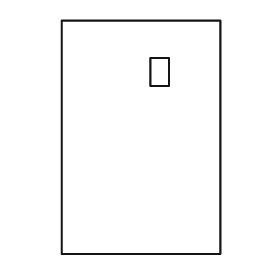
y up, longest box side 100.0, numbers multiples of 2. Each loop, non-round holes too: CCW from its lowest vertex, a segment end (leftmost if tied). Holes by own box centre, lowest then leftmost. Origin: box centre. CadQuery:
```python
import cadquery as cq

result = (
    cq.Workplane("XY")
    .moveTo(-34.0, -50.0)
    .lineTo(34.0, -50.0)
    .lineTo(34.0, 50.0)
    .lineTo(-34.0, 50.0)
    .close()
    .moveTo(4.0, 22.0)
    .lineTo(12.0, 22.0)
    .lineTo(12.0, 34.0)
    .lineTo(4.0, 34.0)
    .close()
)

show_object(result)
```